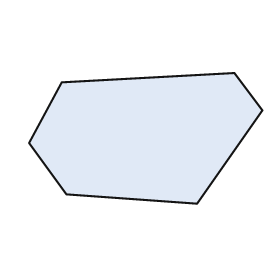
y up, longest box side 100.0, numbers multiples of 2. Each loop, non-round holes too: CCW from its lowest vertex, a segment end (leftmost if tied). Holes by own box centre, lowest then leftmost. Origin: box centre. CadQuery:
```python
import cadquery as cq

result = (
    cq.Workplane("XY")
    .moveTo(22.0, -28.0)
    .lineTo(50.0, 12.0)
    .lineTo(38.0, 28.0)
    .lineTo(-36.0, 24.0)
    .lineTo(-50.0, -2.0)
    .lineTo(-34.0, -24.0)
    .close()
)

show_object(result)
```